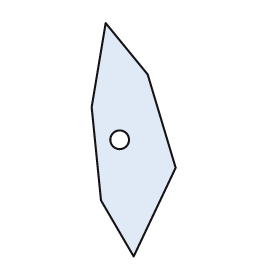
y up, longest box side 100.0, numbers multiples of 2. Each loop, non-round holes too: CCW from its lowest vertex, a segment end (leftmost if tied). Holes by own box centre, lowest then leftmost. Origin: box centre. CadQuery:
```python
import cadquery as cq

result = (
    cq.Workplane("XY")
    .moveTo(0.0, -50.0)
    .lineTo(18.0, -12.0)
    .lineTo(6.0, 28.0)
    .lineTo(-12.0, 50.0)
    .lineTo(-18.0, 14.0)
    .lineTo(-14.0, -26.0)
    .close()
    .moveTo(-6.0, 0.0)
    .circle(4.0)
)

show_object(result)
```